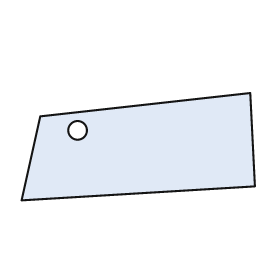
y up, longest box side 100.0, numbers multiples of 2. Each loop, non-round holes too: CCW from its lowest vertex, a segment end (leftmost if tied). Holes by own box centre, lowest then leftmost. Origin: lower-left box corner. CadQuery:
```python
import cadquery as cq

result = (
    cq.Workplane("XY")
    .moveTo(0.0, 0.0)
    .lineTo(100.0, 6.0)
    .lineTo(98.0, 46.0)
    .lineTo(8.0, 36.0)
    .close()
    .moveTo(24.0, 30.0)
    .circle(4.0)
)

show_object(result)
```